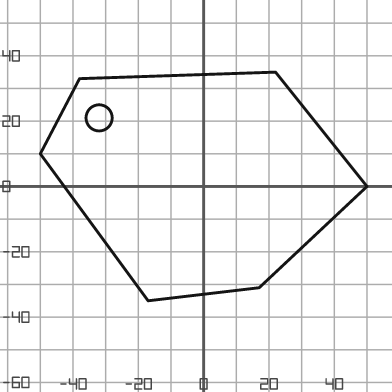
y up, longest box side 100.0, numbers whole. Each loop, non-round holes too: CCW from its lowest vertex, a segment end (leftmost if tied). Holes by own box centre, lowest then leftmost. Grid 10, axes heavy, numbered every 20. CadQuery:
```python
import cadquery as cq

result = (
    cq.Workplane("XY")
    .moveTo(-17.0, -35.0)
    .lineTo(17.0, -31.0)
    .lineTo(50.0, 0.0)
    .lineTo(22.0, 35.0)
    .lineTo(-38.0, 33.0)
    .lineTo(-50.0, 10.0)
    .close()
    .moveTo(-32.0, 21.0)
    .circle(4.0)
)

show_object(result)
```